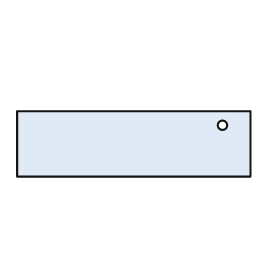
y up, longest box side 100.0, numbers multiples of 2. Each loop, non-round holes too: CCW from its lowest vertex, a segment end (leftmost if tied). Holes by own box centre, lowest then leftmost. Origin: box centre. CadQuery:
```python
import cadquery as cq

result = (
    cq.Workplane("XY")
    .moveTo(-50.0, -14.0)
    .lineTo(50.0, -14.0)
    .lineTo(50.0, 14.0)
    .lineTo(-50.0, 14.0)
    .close()
    .moveTo(38.0, 8.0)
    .circle(2.0)
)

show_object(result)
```